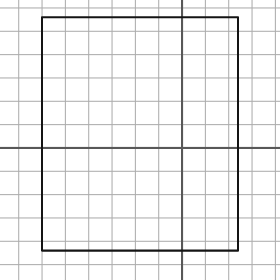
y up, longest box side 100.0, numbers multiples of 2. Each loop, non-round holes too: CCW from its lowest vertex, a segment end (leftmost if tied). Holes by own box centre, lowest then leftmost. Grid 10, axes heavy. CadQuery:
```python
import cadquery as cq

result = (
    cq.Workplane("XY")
    .moveTo(-60.0, -44.0)
    .lineTo(24.0, -44.0)
    .lineTo(24.0, 56.0)
    .lineTo(-60.0, 56.0)
    .close()
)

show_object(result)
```